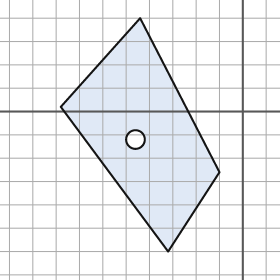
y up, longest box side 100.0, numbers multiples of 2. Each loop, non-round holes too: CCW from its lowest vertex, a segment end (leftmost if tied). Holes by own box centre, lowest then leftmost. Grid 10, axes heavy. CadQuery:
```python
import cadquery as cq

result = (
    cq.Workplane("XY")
    .moveTo(-32.0, -60.0)
    .lineTo(-10.0, -26.0)
    .lineTo(-44.0, 40.0)
    .lineTo(-78.0, 2.0)
    .close()
    .moveTo(-46.0, -12.0)
    .circle(4.0)
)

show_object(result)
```